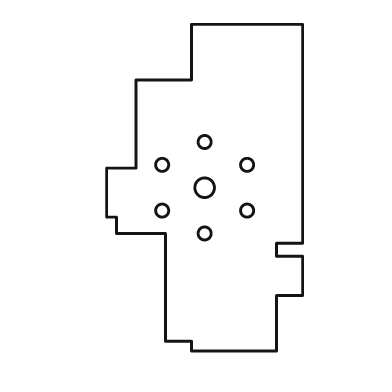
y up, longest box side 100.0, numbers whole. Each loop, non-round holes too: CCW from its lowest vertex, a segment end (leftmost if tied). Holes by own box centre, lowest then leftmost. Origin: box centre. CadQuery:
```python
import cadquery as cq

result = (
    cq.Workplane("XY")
    .moveTo(-4.0, -50.0)
    .lineTo(22.0, -50.0)
    .lineTo(22.0, -33.0)
    .lineTo(30.0, -33.0)
    .lineTo(30.0, -21.0)
    .lineTo(22.0, -21.0)
    .lineTo(22.0, -17.0)
    .lineTo(30.0, -17.0)
    .lineTo(30.0, 50.0)
    .lineTo(-4.0, 50.0)
    .lineTo(-4.0, 33.0)
    .lineTo(-21.0, 33.0)
    .lineTo(-21.0, 6.0)
    .lineTo(-30.0, 6.0)
    .lineTo(-30.0, -9.0)
    .lineTo(-27.0, -9.0)
    .lineTo(-27.0, -14.0)
    .lineTo(-12.0, -14.0)
    .lineTo(-12.0, -47.0)
    .lineTo(-4.0, -47.0)
    .close()
    .moveTo(0.0, -14.0)
    .circle(2.0)
    .moveTo(-13.0, -7.0)
    .circle(2.0)
    .moveTo(13.0, -7.0)
    .circle(2.0)
    .moveTo(0.0, 0.0)
    .circle(3.0)
    .moveTo(-13.0, 7.0)
    .circle(2.0)
    .moveTo(13.0, 7.0)
    .circle(2.0)
    .moveTo(0.0, 14.0)
    .circle(2.0)
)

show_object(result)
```